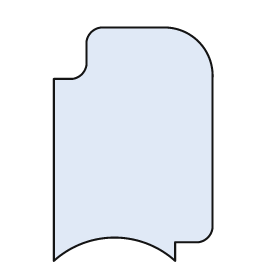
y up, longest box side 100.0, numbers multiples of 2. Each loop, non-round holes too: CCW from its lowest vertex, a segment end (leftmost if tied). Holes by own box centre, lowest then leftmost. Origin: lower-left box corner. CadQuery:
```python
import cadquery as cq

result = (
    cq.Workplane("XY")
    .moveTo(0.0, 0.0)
    .threePointArc((26.0, 10.0), (52.0, 0.0))
    .lineTo(52.0, 8.0)
    .lineTo(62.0, 8.0)
    .threePointArc((66.0, 10.0), (68.0, 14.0))
    .lineTo(68.0, 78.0)
    .threePointArc((62.0, 94.0), (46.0, 100.0))
    .lineTo(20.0, 100.0)
    .threePointArc((16.0, 98.0), (14.0, 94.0))
    .lineTo(14.0, 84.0)
    .threePointArc((12.0, 80.0), (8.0, 78.0))
    .lineTo(0.0, 78.0)
    .close()
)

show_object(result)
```